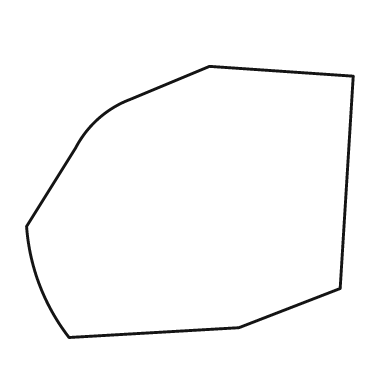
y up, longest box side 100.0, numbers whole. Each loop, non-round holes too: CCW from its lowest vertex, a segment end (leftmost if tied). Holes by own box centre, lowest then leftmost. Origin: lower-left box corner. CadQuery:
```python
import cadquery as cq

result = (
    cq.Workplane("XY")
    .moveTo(13.0, 0.0)
    .lineTo(65.0, 3.0)
    .lineTo(96.0, 15.0)
    .lineTo(100.0, 80.0)
    .lineTo(56.0, 83.0)
    .lineTo(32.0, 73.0)
    .threePointArc((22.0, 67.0), (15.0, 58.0))
    .lineTo(0.0, 34.0)
    .threePointArc((4.0, 16.0), (13.0, 0.0))
    .close()
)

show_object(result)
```